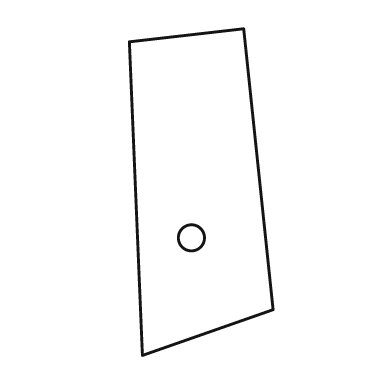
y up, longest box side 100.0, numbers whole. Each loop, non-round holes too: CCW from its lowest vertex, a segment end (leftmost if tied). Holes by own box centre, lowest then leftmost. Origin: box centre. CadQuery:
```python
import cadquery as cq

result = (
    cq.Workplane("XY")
    .moveTo(-18.0, -50.0)
    .lineTo(22.0, -36.0)
    .lineTo(13.0, 50.0)
    .lineTo(-22.0, 46.0)
    .close()
    .moveTo(-3.0, -14.0)
    .circle(4.0)
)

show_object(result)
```